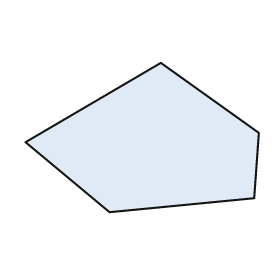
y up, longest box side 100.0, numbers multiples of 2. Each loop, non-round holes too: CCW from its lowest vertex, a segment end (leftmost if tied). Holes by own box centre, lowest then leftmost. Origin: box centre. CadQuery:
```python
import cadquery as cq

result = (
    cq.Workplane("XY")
    .moveTo(-14.0, -32.0)
    .lineTo(48.0, -26.0)
    .lineTo(50.0, 2.0)
    .lineTo(8.0, 32.0)
    .lineTo(-50.0, -2.0)
    .close()
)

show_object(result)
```